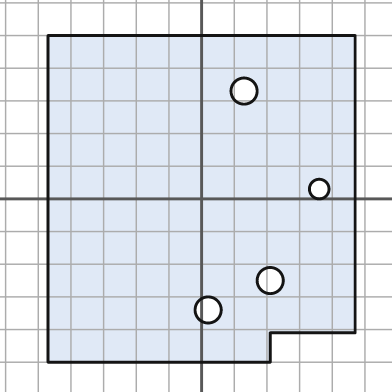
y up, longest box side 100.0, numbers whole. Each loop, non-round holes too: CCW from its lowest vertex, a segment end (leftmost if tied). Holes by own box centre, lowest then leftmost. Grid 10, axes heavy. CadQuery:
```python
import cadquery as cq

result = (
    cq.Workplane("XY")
    .moveTo(-47.0, -50.0)
    .lineTo(21.0, -50.0)
    .lineTo(21.0, -41.0)
    .lineTo(47.0, -41.0)
    .lineTo(47.0, 50.0)
    .lineTo(-47.0, 50.0)
    .close()
    .moveTo(2.0, -34.0)
    .circle(4.0)
    .moveTo(21.0, -25.0)
    .circle(4.0)
    .moveTo(36.0, 3.0)
    .circle(3.0)
    .moveTo(13.0, 33.0)
    .circle(4.0)
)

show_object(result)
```